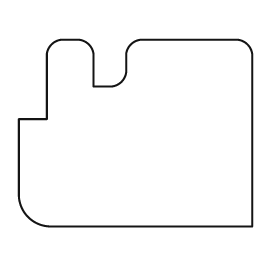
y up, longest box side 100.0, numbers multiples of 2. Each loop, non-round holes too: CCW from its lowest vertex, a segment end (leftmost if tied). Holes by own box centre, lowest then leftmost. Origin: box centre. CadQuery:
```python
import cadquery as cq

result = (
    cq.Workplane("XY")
    .moveTo(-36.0, -40.0)
    .lineTo(50.0, -40.0)
    .lineTo(50.0, 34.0)
    .threePointArc((48.0, 38.0), (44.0, 40.0))
    .lineTo(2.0, 40.0)
    .threePointArc((-2.0, 38.0), (-4.0, 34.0))
    .lineTo(-4.0, 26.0)
    .threePointArc((-6.0, 22.0), (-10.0, 20.0))
    .lineTo(-18.0, 20.0)
    .lineTo(-18.0, 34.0)
    .threePointArc((-20.0, 38.0), (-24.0, 40.0))
    .lineTo(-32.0, 40.0)
    .threePointArc((-36.0, 38.0), (-38.0, 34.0))
    .lineTo(-38.0, 6.0)
    .lineTo(-50.0, 6.0)
    .lineTo(-50.0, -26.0)
    .threePointArc((-46.0, -36.0), (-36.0, -40.0))
    .close()
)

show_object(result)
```